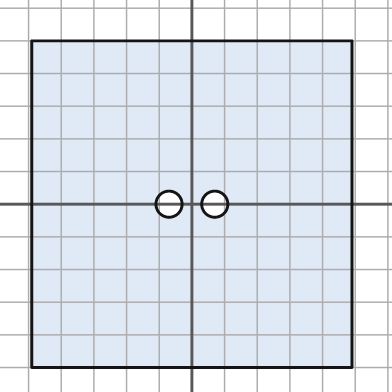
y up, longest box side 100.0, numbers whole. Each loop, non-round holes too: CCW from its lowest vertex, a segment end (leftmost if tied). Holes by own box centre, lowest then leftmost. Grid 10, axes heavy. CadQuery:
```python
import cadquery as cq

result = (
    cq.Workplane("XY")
    .moveTo(-49.0, -50.0)
    .lineTo(49.0, -50.0)
    .lineTo(49.0, 50.0)
    .lineTo(-49.0, 50.0)
    .close()
    .moveTo(-7.0, 0.0)
    .circle(4.0)
    .moveTo(7.0, 0.0)
    .circle(4.0)
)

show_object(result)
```